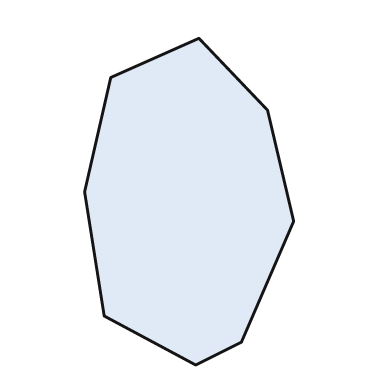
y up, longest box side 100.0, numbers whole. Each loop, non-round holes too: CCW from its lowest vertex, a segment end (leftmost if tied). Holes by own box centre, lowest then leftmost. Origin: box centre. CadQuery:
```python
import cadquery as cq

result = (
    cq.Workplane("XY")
    .moveTo(2.0, -50.0)
    .lineTo(16.0, -43.0)
    .lineTo(32.0, -6.0)
    .lineTo(24.0, 28.0)
    .lineTo(3.0, 50.0)
    .lineTo(-24.0, 38.0)
    .lineTo(-32.0, 3.0)
    .lineTo(-26.0, -35.0)
    .close()
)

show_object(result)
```